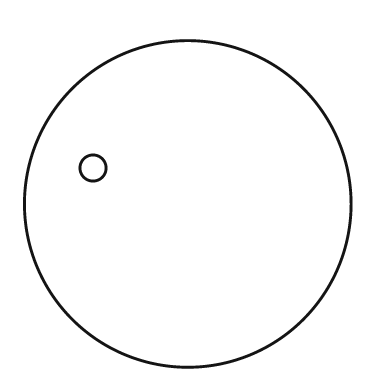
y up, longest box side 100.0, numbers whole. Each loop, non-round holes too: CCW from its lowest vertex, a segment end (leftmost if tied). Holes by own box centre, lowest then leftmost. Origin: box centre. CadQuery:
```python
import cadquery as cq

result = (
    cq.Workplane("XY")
    .moveTo(0.0, 0.0)
    .circle(50.0)
    .moveTo(-29.0, 11.0)
    .circle(4.0)
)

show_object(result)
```